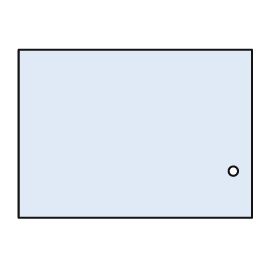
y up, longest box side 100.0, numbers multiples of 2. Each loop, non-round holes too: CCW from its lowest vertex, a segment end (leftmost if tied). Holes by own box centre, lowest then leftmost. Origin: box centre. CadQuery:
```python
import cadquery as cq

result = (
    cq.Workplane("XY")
    .moveTo(-50.0, -36.0)
    .lineTo(50.0, -36.0)
    .lineTo(50.0, 36.0)
    .lineTo(-50.0, 36.0)
    .close()
    .moveTo(42.0, -16.0)
    .circle(2.0)
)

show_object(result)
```